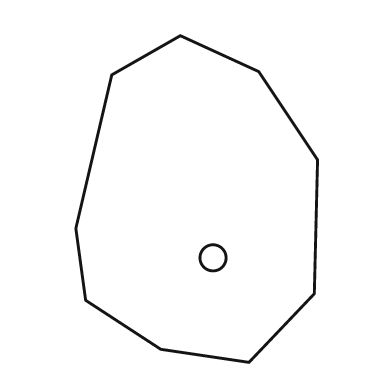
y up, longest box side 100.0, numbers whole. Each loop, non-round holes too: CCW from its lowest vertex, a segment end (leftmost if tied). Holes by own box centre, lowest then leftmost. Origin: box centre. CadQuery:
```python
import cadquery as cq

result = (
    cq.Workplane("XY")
    .moveTo(16.0, -50.0)
    .lineTo(36.0, -29.0)
    .lineTo(37.0, 12.0)
    .lineTo(19.0, 39.0)
    .lineTo(-5.0, 50.0)
    .lineTo(-26.0, 38.0)
    .lineTo(-37.0, -9.0)
    .lineTo(-34.0, -31.0)
    .lineTo(-11.0, -46.0)
    .close()
    .moveTo(5.0, -18.0)
    .circle(4.0)
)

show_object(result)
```